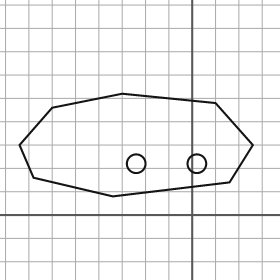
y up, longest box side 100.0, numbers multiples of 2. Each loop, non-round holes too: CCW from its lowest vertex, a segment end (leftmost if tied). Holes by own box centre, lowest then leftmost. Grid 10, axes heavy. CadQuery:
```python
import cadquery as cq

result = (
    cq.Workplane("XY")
    .moveTo(-34.0, 8.0)
    .lineTo(16.0, 14.0)
    .lineTo(26.0, 30.0)
    .lineTo(10.0, 48.0)
    .lineTo(-30.0, 52.0)
    .lineTo(-60.0, 46.0)
    .lineTo(-74.0, 30.0)
    .lineTo(-68.0, 16.0)
    .close()
    .moveTo(-24.0, 22.0)
    .circle(4.0)
    .moveTo(2.0, 22.0)
    .circle(4.0)
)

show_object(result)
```